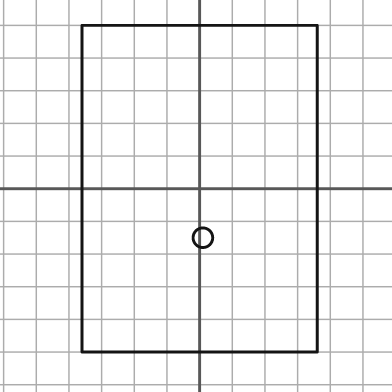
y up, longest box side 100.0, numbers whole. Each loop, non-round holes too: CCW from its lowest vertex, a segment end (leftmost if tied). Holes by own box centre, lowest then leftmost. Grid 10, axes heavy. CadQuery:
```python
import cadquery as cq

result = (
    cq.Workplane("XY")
    .moveTo(-36.0, -50.0)
    .lineTo(36.0, -50.0)
    .lineTo(36.0, 50.0)
    .lineTo(-36.0, 50.0)
    .close()
    .moveTo(1.0, -15.0)
    .circle(3.0)
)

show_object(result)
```